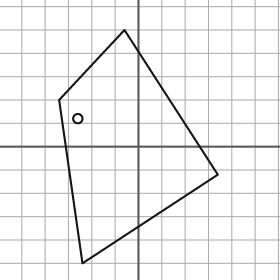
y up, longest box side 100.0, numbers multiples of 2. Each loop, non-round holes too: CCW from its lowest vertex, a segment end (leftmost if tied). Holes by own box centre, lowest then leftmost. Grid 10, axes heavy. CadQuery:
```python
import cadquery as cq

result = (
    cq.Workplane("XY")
    .moveTo(-24.0, -50.0)
    .lineTo(34.0, -12.0)
    .lineTo(-6.0, 50.0)
    .lineTo(-34.0, 20.0)
    .close()
    .moveTo(-26.0, 12.0)
    .circle(2.0)
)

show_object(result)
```